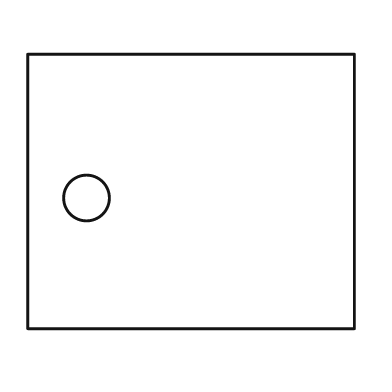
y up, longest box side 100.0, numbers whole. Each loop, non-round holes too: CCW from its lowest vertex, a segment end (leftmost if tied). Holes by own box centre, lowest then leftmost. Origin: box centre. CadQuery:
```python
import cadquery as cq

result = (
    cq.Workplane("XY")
    .moveTo(-50.0, -42.0)
    .lineTo(50.0, -42.0)
    .lineTo(50.0, 42.0)
    .lineTo(-50.0, 42.0)
    .close()
    .moveTo(-32.0, -2.0)
    .circle(7.0)
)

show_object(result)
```